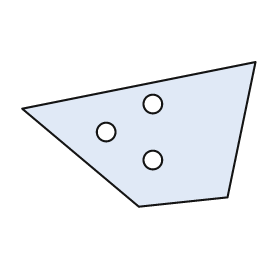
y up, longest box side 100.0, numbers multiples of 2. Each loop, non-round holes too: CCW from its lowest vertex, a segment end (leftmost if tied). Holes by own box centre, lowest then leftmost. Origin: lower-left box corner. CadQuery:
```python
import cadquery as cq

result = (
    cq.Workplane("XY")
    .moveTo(50.0, 0.0)
    .lineTo(88.0, 4.0)
    .lineTo(100.0, 62.0)
    .lineTo(0.0, 42.0)
    .close()
    .moveTo(56.0, 20.0)
    .circle(4.0)
    .moveTo(36.0, 32.0)
    .circle(4.0)
    .moveTo(56.0, 44.0)
    .circle(4.0)
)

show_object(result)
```